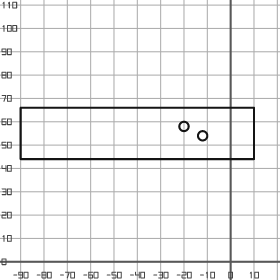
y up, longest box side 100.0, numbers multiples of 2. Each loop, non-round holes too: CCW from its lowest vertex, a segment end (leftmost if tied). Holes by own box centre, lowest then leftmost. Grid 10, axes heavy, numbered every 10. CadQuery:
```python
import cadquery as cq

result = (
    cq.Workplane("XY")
    .moveTo(-90.0, 44.0)
    .lineTo(10.0, 44.0)
    .lineTo(10.0, 66.0)
    .lineTo(-90.0, 66.0)
    .close()
    .moveTo(-12.0, 54.0)
    .circle(2.0)
    .moveTo(-20.0, 58.0)
    .circle(2.0)
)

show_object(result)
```